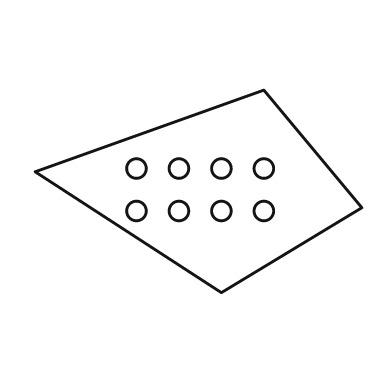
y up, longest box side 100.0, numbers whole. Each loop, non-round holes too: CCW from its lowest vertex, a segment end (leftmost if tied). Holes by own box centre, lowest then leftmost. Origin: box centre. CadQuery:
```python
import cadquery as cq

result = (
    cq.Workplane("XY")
    .moveTo(7.0, -31.0)
    .lineTo(50.0, -5.0)
    .lineTo(20.0, 31.0)
    .lineTo(-50.0, 6.0)
    .close()
    .moveTo(-19.0, -6.0)
    .circle(3.0)
    .moveTo(-6.0, -6.0)
    .circle(3.0)
    .moveTo(7.0, -6.0)
    .circle(3.0)
    .moveTo(20.0, -6.0)
    .circle(3.0)
    .moveTo(-19.0, 7.0)
    .circle(3.0)
    .moveTo(-6.0, 7.0)
    .circle(3.0)
    .moveTo(7.0, 7.0)
    .circle(3.0)
    .moveTo(20.0, 7.0)
    .circle(3.0)
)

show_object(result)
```